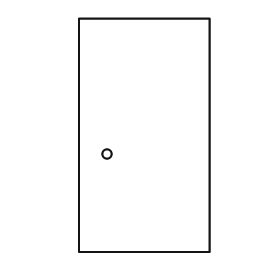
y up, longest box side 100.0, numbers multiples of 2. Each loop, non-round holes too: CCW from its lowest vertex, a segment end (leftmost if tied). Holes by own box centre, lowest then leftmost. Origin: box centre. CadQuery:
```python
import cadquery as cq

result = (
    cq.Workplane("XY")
    .moveTo(-28.0, -50.0)
    .lineTo(28.0, -50.0)
    .lineTo(28.0, 50.0)
    .lineTo(-28.0, 50.0)
    .close()
    .moveTo(-16.0, -8.0)
    .circle(2.0)
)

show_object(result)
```